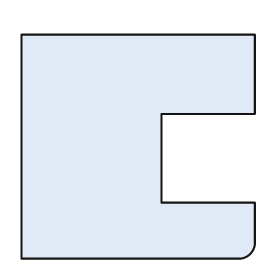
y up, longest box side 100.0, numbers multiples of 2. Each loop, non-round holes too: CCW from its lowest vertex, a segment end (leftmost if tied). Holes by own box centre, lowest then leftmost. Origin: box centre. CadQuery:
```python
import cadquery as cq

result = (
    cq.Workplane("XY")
    .moveTo(-50.0, -48.0)
    .lineTo(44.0, -48.0)
    .threePointArc((48.0, -46.0), (50.0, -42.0))
    .lineTo(50.0, -24.0)
    .lineTo(10.0, -24.0)
    .lineTo(10.0, 14.0)
    .lineTo(50.0, 14.0)
    .lineTo(50.0, 48.0)
    .lineTo(-50.0, 48.0)
    .close()
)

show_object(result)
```